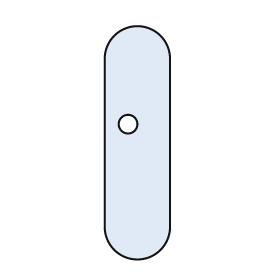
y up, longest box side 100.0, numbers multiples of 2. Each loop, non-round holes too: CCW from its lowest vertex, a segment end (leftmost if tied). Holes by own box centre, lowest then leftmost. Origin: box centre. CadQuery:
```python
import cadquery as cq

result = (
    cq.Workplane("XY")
    .moveTo(-14.0, -36.0)
    .threePointArc((0.0, -50.0), (14.0, -36.0))
    .lineTo(14.0, 36.0)
    .threePointArc((0.0, 50.0), (-14.0, 36.0))
    .close()
    .moveTo(-4.0, 8.0)
    .circle(4.0)
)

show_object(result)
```